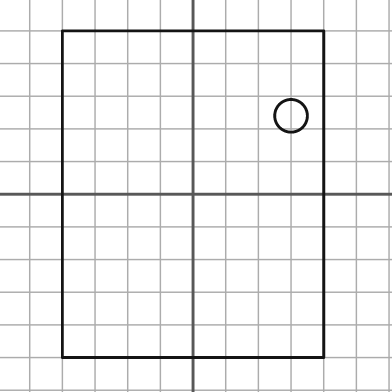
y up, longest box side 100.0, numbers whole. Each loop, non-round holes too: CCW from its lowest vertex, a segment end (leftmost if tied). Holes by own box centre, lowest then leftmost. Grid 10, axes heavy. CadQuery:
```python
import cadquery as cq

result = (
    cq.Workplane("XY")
    .moveTo(-40.0, -50.0)
    .lineTo(40.0, -50.0)
    .lineTo(40.0, 50.0)
    .lineTo(-40.0, 50.0)
    .close()
    .moveTo(30.0, 24.0)
    .circle(5.0)
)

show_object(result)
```